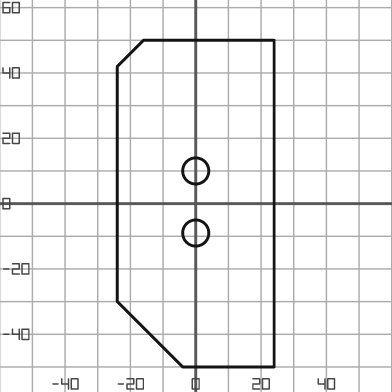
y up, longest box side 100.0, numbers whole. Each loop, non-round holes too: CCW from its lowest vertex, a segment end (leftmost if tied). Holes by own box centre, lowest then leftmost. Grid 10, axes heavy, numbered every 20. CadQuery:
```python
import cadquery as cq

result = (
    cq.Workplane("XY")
    .moveTo(-4.0, -50.0)
    .lineTo(24.0, -50.0)
    .lineTo(24.0, 50.0)
    .lineTo(-16.0, 50.0)
    .lineTo(-24.0, 42.0)
    .lineTo(-24.0, -30.0)
    .close()
    .moveTo(0.0, -9.0)
    .circle(4.0)
    .moveTo(0.0, 10.0)
    .circle(4.0)
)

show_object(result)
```